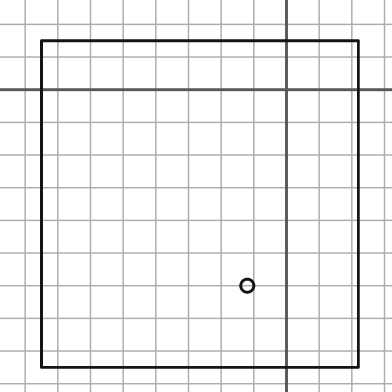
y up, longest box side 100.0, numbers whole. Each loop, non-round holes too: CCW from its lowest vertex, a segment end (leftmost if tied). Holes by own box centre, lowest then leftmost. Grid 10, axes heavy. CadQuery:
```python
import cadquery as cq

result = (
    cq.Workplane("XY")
    .moveTo(-75.0, -85.0)
    .lineTo(22.0, -85.0)
    .lineTo(22.0, 15.0)
    .lineTo(-75.0, 15.0)
    .close()
    .moveTo(-12.0, -60.0)
    .circle(2.0)
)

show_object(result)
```